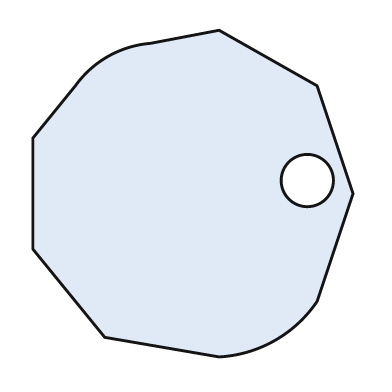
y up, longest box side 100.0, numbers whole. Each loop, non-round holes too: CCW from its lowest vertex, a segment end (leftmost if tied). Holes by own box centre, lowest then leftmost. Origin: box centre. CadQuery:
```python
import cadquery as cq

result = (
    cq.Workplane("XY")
    .moveTo(8.0, -50.0)
    .threePointArc((25.0, -45.0), (38.0, -33.0))
    .lineTo(49.0, 0.0)
    .lineTo(38.0, 33.0)
    .lineTo(8.0, 50.0)
    .lineTo(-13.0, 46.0)
    .threePointArc((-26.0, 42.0), (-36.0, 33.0))
    .lineTo(-49.0, 17.0)
    .lineTo(-49.0, -17.0)
    .lineTo(-27.0, -44.0)
    .close()
    .moveTo(35.0, 4.0)
    .circle(8.0)
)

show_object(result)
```